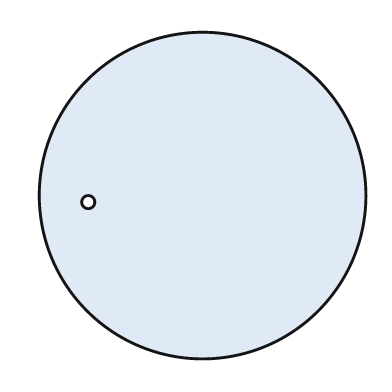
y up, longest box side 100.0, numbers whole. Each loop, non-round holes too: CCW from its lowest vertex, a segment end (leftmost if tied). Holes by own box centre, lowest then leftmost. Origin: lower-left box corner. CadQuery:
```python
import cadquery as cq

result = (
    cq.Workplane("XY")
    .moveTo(50.0, 50.0)
    .circle(50.0)
    .moveTo(15.0, 48.0)
    .circle(2.0)
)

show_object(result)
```